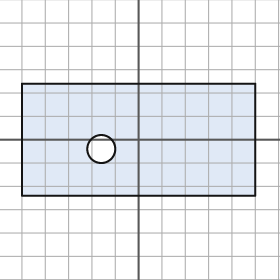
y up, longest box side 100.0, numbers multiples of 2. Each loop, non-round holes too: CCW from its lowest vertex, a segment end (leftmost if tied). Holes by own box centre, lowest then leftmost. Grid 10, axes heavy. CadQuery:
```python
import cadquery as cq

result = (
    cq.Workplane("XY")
    .moveTo(-50.0, -24.0)
    .lineTo(50.0, -24.0)
    .lineTo(50.0, 24.0)
    .lineTo(-50.0, 24.0)
    .close()
    .moveTo(-16.0, -4.0)
    .circle(6.0)
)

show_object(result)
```